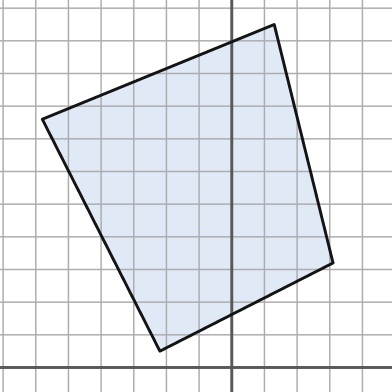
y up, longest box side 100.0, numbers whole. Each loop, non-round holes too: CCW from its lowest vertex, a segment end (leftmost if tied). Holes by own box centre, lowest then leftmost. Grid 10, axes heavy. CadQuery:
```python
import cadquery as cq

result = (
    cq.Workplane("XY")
    .moveTo(-22.0, 5.0)
    .lineTo(31.0, 32.0)
    .lineTo(13.0, 105.0)
    .lineTo(-58.0, 76.0)
    .close()
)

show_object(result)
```